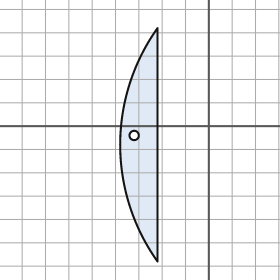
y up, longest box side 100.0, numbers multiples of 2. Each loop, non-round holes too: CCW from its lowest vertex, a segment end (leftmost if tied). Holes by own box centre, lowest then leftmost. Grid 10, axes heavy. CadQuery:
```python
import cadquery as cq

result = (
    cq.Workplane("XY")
    .moveTo(-22.0, -58.0)
    .lineTo(-22.0, 42.0)
    .threePointArc((-38.0, -8.0), (-22.0, -58.0))
    .close()
    .moveTo(-32.0, -4.0)
    .circle(2.0)
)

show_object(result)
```